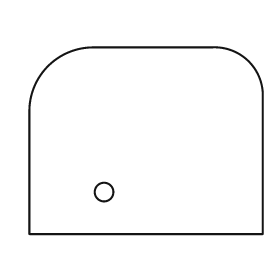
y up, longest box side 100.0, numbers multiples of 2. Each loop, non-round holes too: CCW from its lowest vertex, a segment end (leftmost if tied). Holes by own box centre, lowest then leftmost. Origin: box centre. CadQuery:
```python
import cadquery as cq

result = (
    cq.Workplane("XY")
    .moveTo(-50.0, -40.0)
    .lineTo(50.0, -40.0)
    .lineTo(50.0, 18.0)
    .threePointArc((44.0, 34.0), (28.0, 40.0))
    .lineTo(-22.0, 40.0)
    .threePointArc((-42.0, 32.0), (-50.0, 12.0))
    .close()
    .moveTo(-18.0, -22.0)
    .circle(4.0)
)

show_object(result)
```